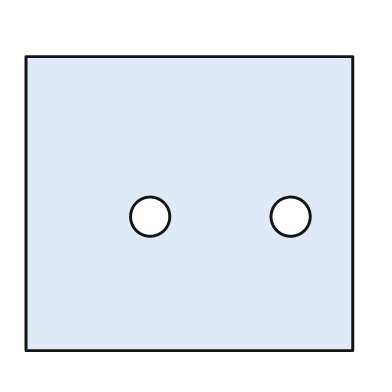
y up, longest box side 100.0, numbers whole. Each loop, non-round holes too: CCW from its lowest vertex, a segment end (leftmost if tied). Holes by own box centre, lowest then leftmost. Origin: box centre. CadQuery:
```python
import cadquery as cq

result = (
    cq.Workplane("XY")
    .moveTo(-50.0, -45.0)
    .lineTo(50.0, -45.0)
    .lineTo(50.0, 45.0)
    .lineTo(-50.0, 45.0)
    .close()
    .moveTo(-12.0, -4.0)
    .circle(6.0)
    .moveTo(31.0, -4.0)
    .circle(6.0)
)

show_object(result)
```